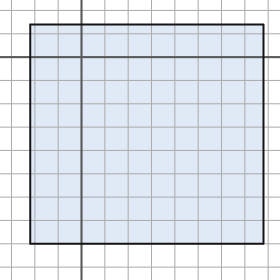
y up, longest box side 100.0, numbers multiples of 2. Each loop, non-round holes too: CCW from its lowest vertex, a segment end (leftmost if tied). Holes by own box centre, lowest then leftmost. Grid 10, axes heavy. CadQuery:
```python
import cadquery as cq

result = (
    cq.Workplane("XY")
    .moveTo(-22.0, -80.0)
    .lineTo(78.0, -80.0)
    .lineTo(78.0, 14.0)
    .lineTo(-22.0, 14.0)
    .close()
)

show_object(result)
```